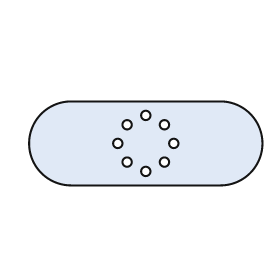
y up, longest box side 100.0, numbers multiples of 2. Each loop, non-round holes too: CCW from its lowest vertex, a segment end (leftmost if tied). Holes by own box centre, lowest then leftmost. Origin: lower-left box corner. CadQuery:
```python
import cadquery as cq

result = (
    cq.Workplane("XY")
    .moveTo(18.0, 0.0)
    .lineTo(82.0, 0.0)
    .threePointArc((100.0, 18.0), (82.0, 36.0))
    .lineTo(18.0, 36.0)
    .threePointArc((0.0, 18.0), (18.0, 0.0))
    .close()
    .moveTo(50.0, 6.0)
    .circle(2.0)
    .moveTo(42.0, 10.0)
    .circle(2.0)
    .moveTo(58.0, 10.0)
    .circle(2.0)
    .moveTo(38.0, 18.0)
    .circle(2.0)
    .moveTo(62.0, 18.0)
    .circle(2.0)
    .moveTo(42.0, 26.0)
    .circle(2.0)
    .moveTo(58.0, 26.0)
    .circle(2.0)
    .moveTo(50.0, 30.0)
    .circle(2.0)
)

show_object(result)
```